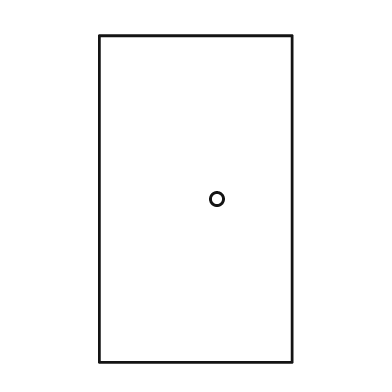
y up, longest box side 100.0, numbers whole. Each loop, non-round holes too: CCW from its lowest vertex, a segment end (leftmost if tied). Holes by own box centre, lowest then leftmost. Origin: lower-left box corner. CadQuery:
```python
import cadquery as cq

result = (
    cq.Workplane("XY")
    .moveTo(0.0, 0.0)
    .lineTo(59.0, 0.0)
    .lineTo(59.0, 100.0)
    .lineTo(0.0, 100.0)
    .close()
    .moveTo(36.0, 50.0)
    .circle(2.0)
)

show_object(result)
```